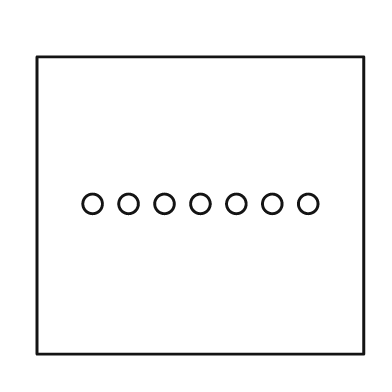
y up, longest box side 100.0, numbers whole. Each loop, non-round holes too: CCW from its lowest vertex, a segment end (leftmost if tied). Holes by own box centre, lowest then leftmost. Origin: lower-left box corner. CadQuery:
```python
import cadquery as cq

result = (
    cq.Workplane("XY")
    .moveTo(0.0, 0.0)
    .lineTo(100.0, 0.0)
    .lineTo(100.0, 91.0)
    .lineTo(0.0, 91.0)
    .close()
    .moveTo(17.0, 46.0)
    .circle(3.0)
    .moveTo(28.0, 46.0)
    .circle(3.0)
    .moveTo(39.0, 46.0)
    .circle(3.0)
    .moveTo(50.0, 46.0)
    .circle(3.0)
    .moveTo(61.0, 46.0)
    .circle(3.0)
    .moveTo(72.0, 46.0)
    .circle(3.0)
    .moveTo(83.0, 46.0)
    .circle(3.0)
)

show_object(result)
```